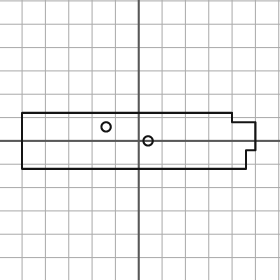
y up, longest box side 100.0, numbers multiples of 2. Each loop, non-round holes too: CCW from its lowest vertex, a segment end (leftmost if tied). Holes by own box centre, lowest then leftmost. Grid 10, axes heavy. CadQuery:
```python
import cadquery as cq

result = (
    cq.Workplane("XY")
    .moveTo(-50.0, -12.0)
    .lineTo(46.0, -12.0)
    .lineTo(46.0, -4.0)
    .lineTo(50.0, -4.0)
    .lineTo(50.0, 8.0)
    .lineTo(40.0, 8.0)
    .lineTo(40.0, 12.0)
    .lineTo(-50.0, 12.0)
    .close()
    .moveTo(4.0, 0.0)
    .circle(2.0)
    .moveTo(-14.0, 6.0)
    .circle(2.0)
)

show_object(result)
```